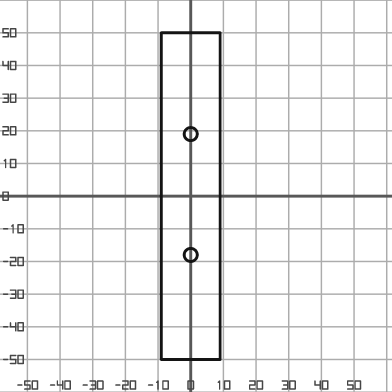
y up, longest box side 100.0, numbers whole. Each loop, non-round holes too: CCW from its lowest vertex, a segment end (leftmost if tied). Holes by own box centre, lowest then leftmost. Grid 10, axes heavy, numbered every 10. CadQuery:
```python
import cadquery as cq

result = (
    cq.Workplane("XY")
    .moveTo(-9.0, -50.0)
    .lineTo(9.0, -50.0)
    .lineTo(9.0, 50.0)
    .lineTo(-9.0, 50.0)
    .close()
    .moveTo(0.0, -18.0)
    .circle(2.0)
    .moveTo(0.0, 19.0)
    .circle(2.0)
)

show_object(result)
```